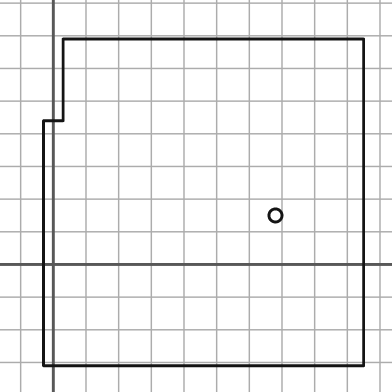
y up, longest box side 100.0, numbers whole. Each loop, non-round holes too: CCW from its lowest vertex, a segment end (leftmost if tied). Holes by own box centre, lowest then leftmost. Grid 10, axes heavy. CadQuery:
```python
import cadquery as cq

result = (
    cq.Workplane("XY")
    .moveTo(-3.0, -31.0)
    .lineTo(95.0, -31.0)
    .lineTo(95.0, 69.0)
    .lineTo(3.0, 69.0)
    .lineTo(3.0, 44.0)
    .lineTo(-3.0, 44.0)
    .close()
    .moveTo(68.0, 15.0)
    .circle(2.0)
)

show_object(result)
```